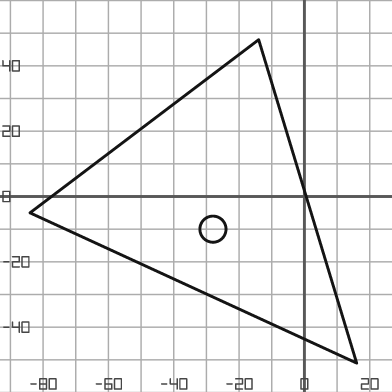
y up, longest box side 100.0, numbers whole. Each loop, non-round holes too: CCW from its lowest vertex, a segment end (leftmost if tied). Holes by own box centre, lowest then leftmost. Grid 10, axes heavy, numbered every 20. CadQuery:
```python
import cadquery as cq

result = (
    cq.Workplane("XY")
    .moveTo(16.0, -51.0)
    .lineTo(-14.0, 48.0)
    .lineTo(-84.0, -5.0)
    .close()
    .moveTo(-28.0, -10.0)
    .circle(4.0)
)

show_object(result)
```